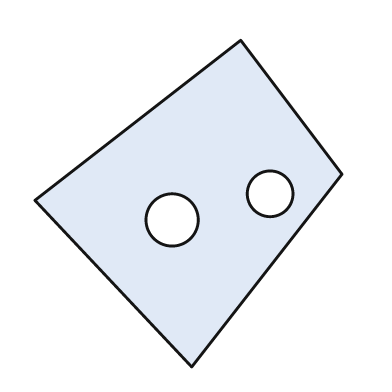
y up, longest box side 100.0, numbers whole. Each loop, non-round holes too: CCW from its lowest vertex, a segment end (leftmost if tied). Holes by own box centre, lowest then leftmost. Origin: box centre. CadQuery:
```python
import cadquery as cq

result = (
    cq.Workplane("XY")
    .moveTo(1.0, -50.0)
    .lineTo(47.0, 9.0)
    .lineTo(16.0, 50.0)
    .lineTo(-47.0, 1.0)
    .close()
    .moveTo(-5.0, -5.0)
    .circle(8.0)
    .moveTo(25.0, 3.0)
    .circle(7.0)
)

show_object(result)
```